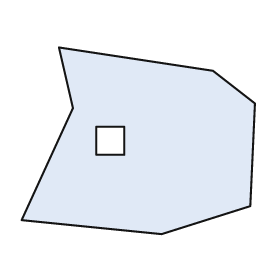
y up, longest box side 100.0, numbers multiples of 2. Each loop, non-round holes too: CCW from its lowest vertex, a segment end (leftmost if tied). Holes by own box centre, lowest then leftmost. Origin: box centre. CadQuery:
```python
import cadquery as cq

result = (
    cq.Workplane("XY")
    .moveTo(10.0, -40.0)
    .lineTo(48.0, -28.0)
    .lineTo(50.0, 16.0)
    .lineTo(32.0, 30.0)
    .lineTo(-34.0, 40.0)
    .lineTo(-28.0, 14.0)
    .lineTo(-50.0, -34.0)
    .close()
    .moveTo(-18.0, -6.0)
    .lineTo(-6.0, -6.0)
    .lineTo(-6.0, 6.0)
    .lineTo(-18.0, 6.0)
    .close()
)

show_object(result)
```